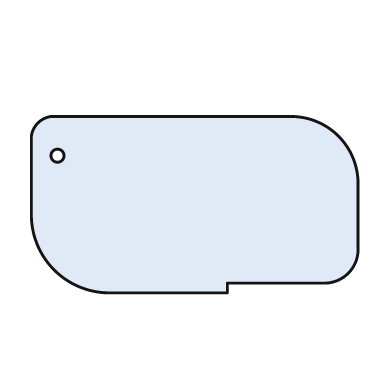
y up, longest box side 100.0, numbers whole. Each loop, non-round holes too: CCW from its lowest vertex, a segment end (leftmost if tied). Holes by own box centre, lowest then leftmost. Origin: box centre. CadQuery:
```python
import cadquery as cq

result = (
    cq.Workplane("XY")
    .moveTo(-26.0, -27.0)
    .lineTo(10.0, -27.0)
    .lineTo(10.0, -24.0)
    .lineTo(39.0, -24.0)
    .threePointArc((47.0, -21.0), (50.0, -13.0))
    .lineTo(50.0, 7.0)
    .threePointArc((44.0, 21.0), (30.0, 27.0))
    .lineTo(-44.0, 27.0)
    .threePointArc((-48.0, 25.0), (-50.0, 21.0))
    .lineTo(-50.0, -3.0)
    .threePointArc((-43.0, -20.0), (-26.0, -27.0))
    .close()
    .moveTo(-42.0, 15.0)
    .circle(2.0)
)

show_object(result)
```